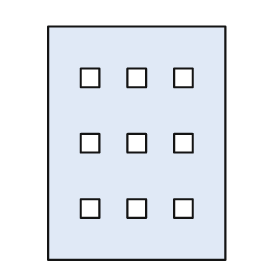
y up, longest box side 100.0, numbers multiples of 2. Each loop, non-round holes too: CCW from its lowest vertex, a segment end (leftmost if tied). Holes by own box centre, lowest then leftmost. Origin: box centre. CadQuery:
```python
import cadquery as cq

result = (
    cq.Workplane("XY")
    .moveTo(-38.0, -50.0)
    .lineTo(38.0, -50.0)
    .lineTo(38.0, 50.0)
    .lineTo(-38.0, 50.0)
    .close()
    .moveTo(-24.0, -32.0)
    .lineTo(-16.0, -32.0)
    .lineTo(-16.0, -24.0)
    .lineTo(-24.0, -24.0)
    .close()
    .moveTo(-4.0, -32.0)
    .lineTo(4.0, -32.0)
    .lineTo(4.0, -24.0)
    .lineTo(-4.0, -24.0)
    .close()
    .moveTo(16.0, -32.0)
    .lineTo(24.0, -32.0)
    .lineTo(24.0, -24.0)
    .lineTo(16.0, -24.0)
    .close()
    .moveTo(-24.0, -4.0)
    .lineTo(-16.0, -4.0)
    .lineTo(-16.0, 4.0)
    .lineTo(-24.0, 4.0)
    .close()
    .moveTo(-4.0, -4.0)
    .lineTo(4.0, -4.0)
    .lineTo(4.0, 4.0)
    .lineTo(-4.0, 4.0)
    .close()
    .moveTo(16.0, -4.0)
    .lineTo(24.0, -4.0)
    .lineTo(24.0, 4.0)
    .lineTo(16.0, 4.0)
    .close()
    .moveTo(-24.0, 24.0)
    .lineTo(-16.0, 24.0)
    .lineTo(-16.0, 32.0)
    .lineTo(-24.0, 32.0)
    .close()
    .moveTo(-4.0, 24.0)
    .lineTo(4.0, 24.0)
    .lineTo(4.0, 32.0)
    .lineTo(-4.0, 32.0)
    .close()
    .moveTo(16.0, 24.0)
    .lineTo(24.0, 24.0)
    .lineTo(24.0, 32.0)
    .lineTo(16.0, 32.0)
    .close()
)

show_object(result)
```